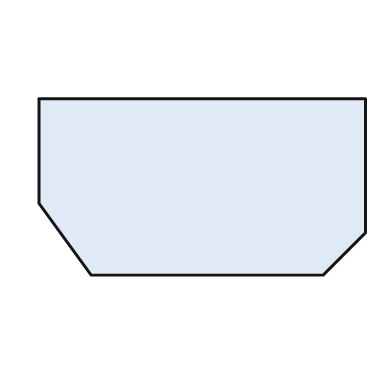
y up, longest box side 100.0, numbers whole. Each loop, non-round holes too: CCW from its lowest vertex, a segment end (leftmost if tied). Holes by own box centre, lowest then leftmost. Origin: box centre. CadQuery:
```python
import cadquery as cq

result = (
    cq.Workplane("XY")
    .moveTo(-34.0, -27.0)
    .lineTo(37.0, -27.0)
    .lineTo(50.0, -14.0)
    .lineTo(50.0, 27.0)
    .lineTo(-50.0, 27.0)
    .lineTo(-50.0, -5.0)
    .close()
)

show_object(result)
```